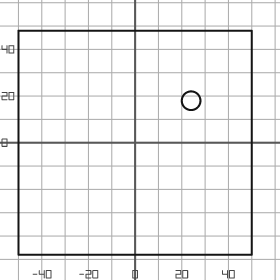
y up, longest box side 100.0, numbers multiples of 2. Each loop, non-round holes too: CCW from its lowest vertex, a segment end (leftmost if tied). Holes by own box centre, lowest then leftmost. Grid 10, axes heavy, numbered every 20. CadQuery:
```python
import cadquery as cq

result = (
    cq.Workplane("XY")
    .moveTo(-50.0, -48.0)
    .lineTo(50.0, -48.0)
    .lineTo(50.0, 48.0)
    .lineTo(-50.0, 48.0)
    .close()
    .moveTo(24.0, 18.0)
    .circle(4.0)
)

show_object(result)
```